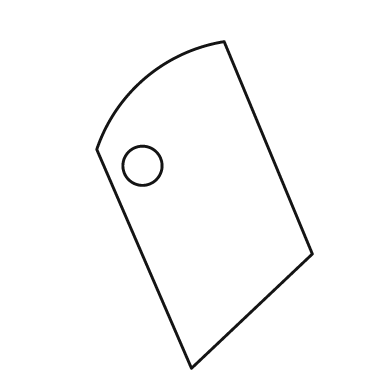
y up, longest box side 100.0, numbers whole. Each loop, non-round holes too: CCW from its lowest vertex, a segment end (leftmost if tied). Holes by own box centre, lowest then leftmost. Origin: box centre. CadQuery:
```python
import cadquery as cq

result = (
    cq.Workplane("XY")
    .moveTo(-4.0, -50.0)
    .lineTo(33.0, -15.0)
    .lineTo(6.0, 50.0)
    .threePointArc((-18.0, 39.0), (-33.0, 17.0))
    .close()
    .moveTo(-19.0, 12.0)
    .circle(6.0)
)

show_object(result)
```